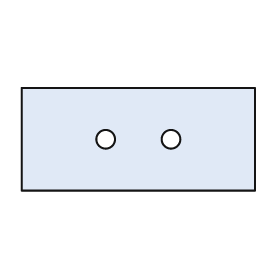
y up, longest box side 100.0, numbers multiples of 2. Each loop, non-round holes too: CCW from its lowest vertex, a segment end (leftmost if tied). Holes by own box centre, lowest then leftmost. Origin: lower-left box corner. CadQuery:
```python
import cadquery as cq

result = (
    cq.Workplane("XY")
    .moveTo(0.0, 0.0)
    .lineTo(100.0, 0.0)
    .lineTo(100.0, 44.0)
    .lineTo(0.0, 44.0)
    .close()
    .moveTo(36.0, 22.0)
    .circle(4.0)
    .moveTo(64.0, 22.0)
    .circle(4.0)
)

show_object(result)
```